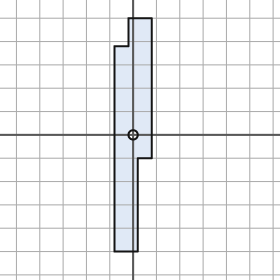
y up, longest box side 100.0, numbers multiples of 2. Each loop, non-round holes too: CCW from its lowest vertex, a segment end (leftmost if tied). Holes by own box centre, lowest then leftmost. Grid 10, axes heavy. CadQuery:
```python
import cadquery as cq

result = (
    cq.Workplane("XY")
    .moveTo(-8.0, -50.0)
    .lineTo(2.0, -50.0)
    .lineTo(2.0, -10.0)
    .lineTo(8.0, -10.0)
    .lineTo(8.0, 50.0)
    .lineTo(-2.0, 50.0)
    .lineTo(-2.0, 38.0)
    .lineTo(-8.0, 38.0)
    .close()
    .moveTo(0.0, 0.0)
    .circle(2.0)
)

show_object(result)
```